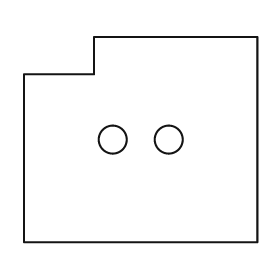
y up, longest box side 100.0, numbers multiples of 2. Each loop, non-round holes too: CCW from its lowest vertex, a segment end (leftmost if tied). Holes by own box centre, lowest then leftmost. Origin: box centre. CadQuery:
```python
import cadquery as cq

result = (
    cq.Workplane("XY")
    .moveTo(-50.0, -44.0)
    .lineTo(50.0, -44.0)
    .lineTo(50.0, 44.0)
    .lineTo(-20.0, 44.0)
    .lineTo(-20.0, 28.0)
    .lineTo(-50.0, 28.0)
    .close()
    .moveTo(-12.0, 0.0)
    .circle(6.0)
    .moveTo(12.0, 0.0)
    .circle(6.0)
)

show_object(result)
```